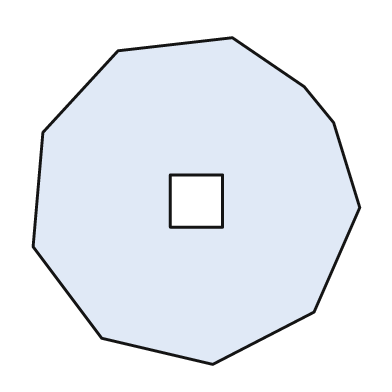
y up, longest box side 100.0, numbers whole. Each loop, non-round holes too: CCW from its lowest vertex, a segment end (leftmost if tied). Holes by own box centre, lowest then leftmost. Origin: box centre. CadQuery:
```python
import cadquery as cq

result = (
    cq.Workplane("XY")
    .moveTo(5.0, -50.0)
    .lineTo(36.0, -34.0)
    .lineTo(50.0, -2.0)
    .lineTo(42.0, 24.0)
    .lineTo(33.0, 35.0)
    .lineTo(11.0, 50.0)
    .lineTo(-24.0, 46.0)
    .lineTo(-47.0, 21.0)
    .lineTo(-50.0, -14.0)
    .lineTo(-29.0, -42.0)
    .close()
    .moveTo(-8.0, -8.0)
    .lineTo(8.0, -8.0)
    .lineTo(8.0, 8.0)
    .lineTo(-8.0, 8.0)
    .close()
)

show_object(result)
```